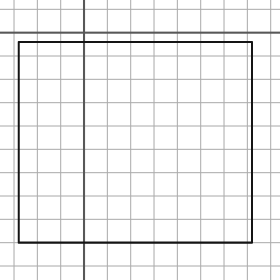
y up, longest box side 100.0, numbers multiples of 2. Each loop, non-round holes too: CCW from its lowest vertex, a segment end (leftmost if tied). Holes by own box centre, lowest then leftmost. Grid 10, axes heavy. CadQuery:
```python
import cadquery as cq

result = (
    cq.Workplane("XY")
    .moveTo(-28.0, -90.0)
    .lineTo(72.0, -90.0)
    .lineTo(72.0, -4.0)
    .lineTo(-28.0, -4.0)
    .close()
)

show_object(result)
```